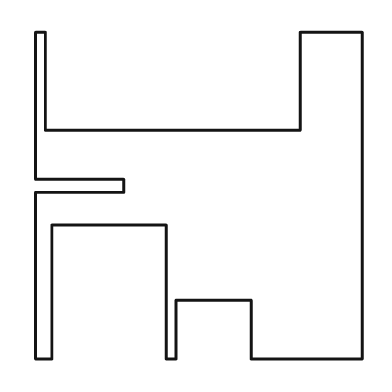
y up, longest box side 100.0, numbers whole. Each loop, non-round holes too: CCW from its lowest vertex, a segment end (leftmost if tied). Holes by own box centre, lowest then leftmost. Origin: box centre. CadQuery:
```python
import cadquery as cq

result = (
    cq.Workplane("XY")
    .moveTo(-50.0, -50.0)
    .lineTo(-45.0, -50.0)
    .lineTo(-45.0, -9.0)
    .lineTo(-10.0, -9.0)
    .lineTo(-10.0, -50.0)
    .lineTo(-7.0, -50.0)
    .lineTo(-7.0, -32.0)
    .lineTo(16.0, -32.0)
    .lineTo(16.0, -50.0)
    .lineTo(50.0, -50.0)
    .lineTo(50.0, 50.0)
    .lineTo(31.0, 50.0)
    .lineTo(31.0, 20.0)
    .lineTo(-47.0, 20.0)
    .lineTo(-47.0, 50.0)
    .lineTo(-50.0, 50.0)
    .lineTo(-50.0, 5.0)
    .lineTo(-23.0, 5.0)
    .lineTo(-23.0, 1.0)
    .lineTo(-50.0, 1.0)
    .close()
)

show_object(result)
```